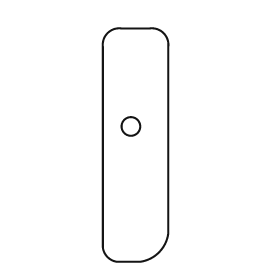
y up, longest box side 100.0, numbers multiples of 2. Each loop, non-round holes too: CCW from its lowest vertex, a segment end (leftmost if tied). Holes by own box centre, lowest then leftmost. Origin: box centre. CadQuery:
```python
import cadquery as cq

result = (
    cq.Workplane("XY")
    .moveTo(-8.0, -50.0)
    .lineTo(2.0, -50.0)
    .threePointArc((10.0, -46.0), (14.0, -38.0))
    .lineTo(14.0, 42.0)
    .threePointArc((12.0, 48.0), (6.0, 50.0))
    .lineTo(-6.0, 50.0)
    .threePointArc((-12.0, 48.0), (-14.0, 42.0))
    .lineTo(-14.0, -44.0)
    .threePointArc((-12.0, -48.0), (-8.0, -50.0))
    .close()
    .moveTo(-2.0, 8.0)
    .circle(4.0)
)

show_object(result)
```